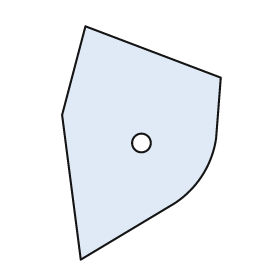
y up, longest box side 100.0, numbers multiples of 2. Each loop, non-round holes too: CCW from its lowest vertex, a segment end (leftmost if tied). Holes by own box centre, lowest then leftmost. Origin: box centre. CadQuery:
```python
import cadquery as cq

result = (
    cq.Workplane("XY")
    .moveTo(-26.0, -50.0)
    .lineTo(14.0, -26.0)
    .threePointArc((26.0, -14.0), (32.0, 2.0))
    .lineTo(34.0, 28.0)
    .lineTo(-24.0, 50.0)
    .lineTo(-34.0, 12.0)
    .close()
    .moveTo(0.0, 0.0)
    .circle(4.0)
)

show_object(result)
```